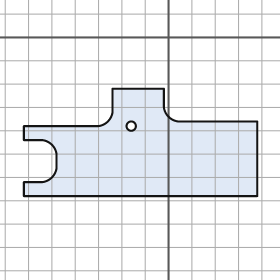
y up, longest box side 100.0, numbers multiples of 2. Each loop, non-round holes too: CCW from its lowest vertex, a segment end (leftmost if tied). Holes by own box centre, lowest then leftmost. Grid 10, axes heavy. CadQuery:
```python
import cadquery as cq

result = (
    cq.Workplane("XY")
    .moveTo(-62.0, -68.0)
    .lineTo(38.0, -68.0)
    .lineTo(38.0, -36.0)
    .lineTo(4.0, -36.0)
    .threePointArc((0.0, -34.0), (-2.0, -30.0))
    .lineTo(-2.0, -22.0)
    .lineTo(-24.0, -22.0)
    .lineTo(-24.0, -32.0)
    .threePointArc((-26.0, -36.0), (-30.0, -38.0))
    .lineTo(-62.0, -38.0)
    .lineTo(-62.0, -44.0)
    .lineTo(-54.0, -44.0)
    .threePointArc((-50.0, -46.0), (-48.0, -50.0))
    .lineTo(-48.0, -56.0)
    .threePointArc((-50.0, -60.0), (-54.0, -62.0))
    .lineTo(-62.0, -62.0)
    .close()
    .moveTo(-16.0, -38.0)
    .circle(2.0)
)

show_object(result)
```